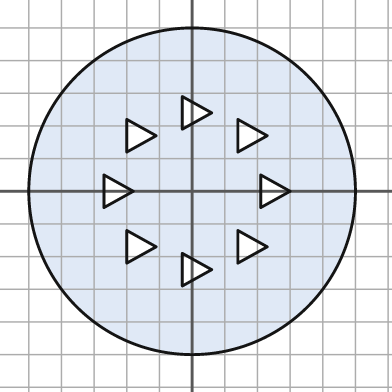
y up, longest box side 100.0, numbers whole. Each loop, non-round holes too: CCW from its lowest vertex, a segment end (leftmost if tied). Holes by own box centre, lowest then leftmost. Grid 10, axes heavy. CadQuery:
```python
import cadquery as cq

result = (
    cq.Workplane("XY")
    .moveTo(0.0, 0.0)
    .circle(50.0)
    .moveTo(-3.0, -29.0)
    .lineTo(6.0, -24.0)
    .lineTo(-3.0, -19.0)
    .close()
    .moveTo(-20.0, -22.0)
    .lineTo(-11.0, -17.0)
    .lineTo(-20.0, -12.0)
    .close()
    .moveTo(14.0, -22.0)
    .lineTo(23.0, -17.0)
    .lineTo(14.0, -12.0)
    .close()
    .moveTo(-27.0, -5.0)
    .lineTo(-18.0, 0.0)
    .lineTo(-27.0, 5.0)
    .close()
    .moveTo(21.0, -5.0)
    .lineTo(30.0, 0.0)
    .lineTo(21.0, 5.0)
    .close()
    .moveTo(-20.0, 12.0)
    .lineTo(-11.0, 17.0)
    .lineTo(-20.0, 22.0)
    .close()
    .moveTo(14.0, 12.0)
    .lineTo(23.0, 17.0)
    .lineTo(14.0, 22.0)
    .close()
    .moveTo(-3.0, 19.0)
    .lineTo(6.0, 24.0)
    .lineTo(-3.0, 29.0)
    .close()
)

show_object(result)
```